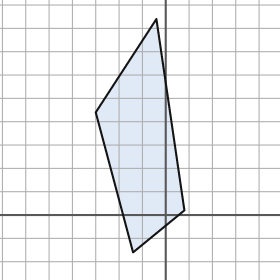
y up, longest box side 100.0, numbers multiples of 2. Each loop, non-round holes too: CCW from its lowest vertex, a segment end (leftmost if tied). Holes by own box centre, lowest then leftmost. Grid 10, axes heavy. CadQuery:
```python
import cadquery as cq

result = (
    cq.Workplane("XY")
    .moveTo(-14.0, -16.0)
    .lineTo(8.0, 2.0)
    .lineTo(-4.0, 84.0)
    .lineTo(-30.0, 44.0)
    .close()
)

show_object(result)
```